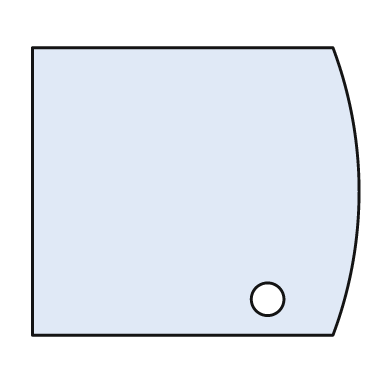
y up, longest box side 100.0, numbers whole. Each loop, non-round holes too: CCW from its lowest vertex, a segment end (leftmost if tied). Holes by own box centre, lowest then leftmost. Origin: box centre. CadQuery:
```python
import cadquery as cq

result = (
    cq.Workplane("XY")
    .moveTo(-50.0, -44.0)
    .lineTo(42.0, -44.0)
    .threePointArc((50.0, 0.0), (42.0, 44.0))
    .lineTo(-50.0, 44.0)
    .close()
    .moveTo(22.0, -33.0)
    .circle(5.0)
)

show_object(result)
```